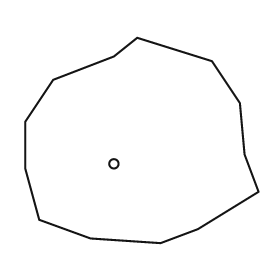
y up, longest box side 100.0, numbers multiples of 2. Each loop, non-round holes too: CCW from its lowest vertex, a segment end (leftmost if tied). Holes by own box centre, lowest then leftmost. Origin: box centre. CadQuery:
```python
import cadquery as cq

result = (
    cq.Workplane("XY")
    .moveTo(8.0, -44.0)
    .lineTo(24.0, -38.0)
    .lineTo(50.0, -22.0)
    .lineTo(44.0, -6.0)
    .lineTo(42.0, 16.0)
    .lineTo(30.0, 34.0)
    .lineTo(-2.0, 44.0)
    .lineTo(-12.0, 36.0)
    .lineTo(-38.0, 26.0)
    .lineTo(-50.0, 8.0)
    .lineTo(-50.0, -12.0)
    .lineTo(-44.0, -34.0)
    .lineTo(-22.0, -42.0)
    .close()
    .moveTo(-12.0, -10.0)
    .circle(2.0)
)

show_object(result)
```